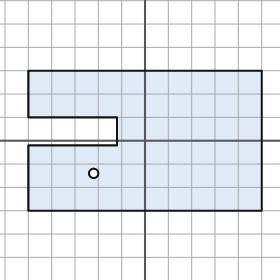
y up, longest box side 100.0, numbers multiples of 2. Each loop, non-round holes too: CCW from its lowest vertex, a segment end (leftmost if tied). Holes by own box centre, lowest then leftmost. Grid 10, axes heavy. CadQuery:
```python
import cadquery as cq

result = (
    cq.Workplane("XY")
    .moveTo(-50.0, -30.0)
    .lineTo(50.0, -30.0)
    .lineTo(50.0, 30.0)
    .lineTo(-50.0, 30.0)
    .lineTo(-50.0, 10.0)
    .lineTo(-12.0, 10.0)
    .lineTo(-12.0, -2.0)
    .lineTo(-50.0, -2.0)
    .close()
    .moveTo(-22.0, -14.0)
    .circle(2.0)
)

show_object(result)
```